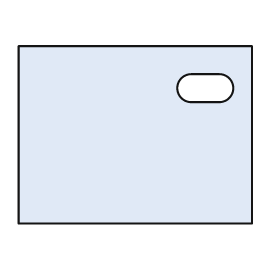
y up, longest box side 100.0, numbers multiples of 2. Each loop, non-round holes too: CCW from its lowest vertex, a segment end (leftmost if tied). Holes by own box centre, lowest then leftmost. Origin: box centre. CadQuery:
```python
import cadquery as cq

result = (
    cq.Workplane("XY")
    .moveTo(-50.0, -38.0)
    .lineTo(50.0, -38.0)
    .lineTo(50.0, 38.0)
    .lineTo(-50.0, 38.0)
    .close()
    .moveTo(24.0, 14.0)
    .lineTo(36.0, 14.0)
    .threePointArc((42.0, 20.0), (36.0, 26.0))
    .lineTo(24.0, 26.0)
    .threePointArc((18.0, 20.0), (24.0, 14.0))
    .close()
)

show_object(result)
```